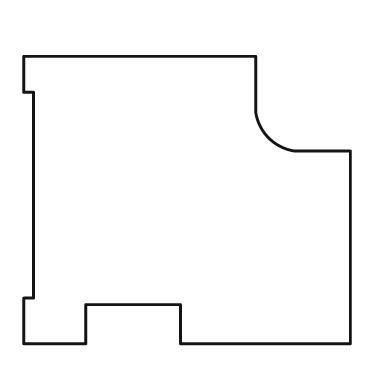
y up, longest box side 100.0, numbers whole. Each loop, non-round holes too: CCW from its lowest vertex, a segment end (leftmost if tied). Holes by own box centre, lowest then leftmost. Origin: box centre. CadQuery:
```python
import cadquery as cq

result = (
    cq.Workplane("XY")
    .moveTo(-50.0, -44.0)
    .lineTo(-31.0, -44.0)
    .lineTo(-31.0, -32.0)
    .lineTo(-2.0, -32.0)
    .lineTo(-2.0, -44.0)
    .lineTo(50.0, -44.0)
    .lineTo(50.0, 15.0)
    .lineTo(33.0, 15.0)
    .threePointArc((25.0, 19.0), (21.0, 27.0))
    .lineTo(21.0, 44.0)
    .lineTo(-50.0, 44.0)
    .lineTo(-50.0, 33.0)
    .lineTo(-47.0, 33.0)
    .lineTo(-47.0, -30.0)
    .lineTo(-50.0, -30.0)
    .close()
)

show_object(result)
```